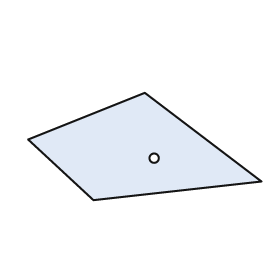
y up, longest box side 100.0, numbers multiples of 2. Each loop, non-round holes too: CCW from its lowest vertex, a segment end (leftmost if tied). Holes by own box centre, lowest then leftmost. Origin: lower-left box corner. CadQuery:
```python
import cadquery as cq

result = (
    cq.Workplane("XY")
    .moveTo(28.0, 0.0)
    .lineTo(100.0, 8.0)
    .lineTo(50.0, 46.0)
    .lineTo(0.0, 26.0)
    .close()
    .moveTo(54.0, 18.0)
    .circle(2.0)
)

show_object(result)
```